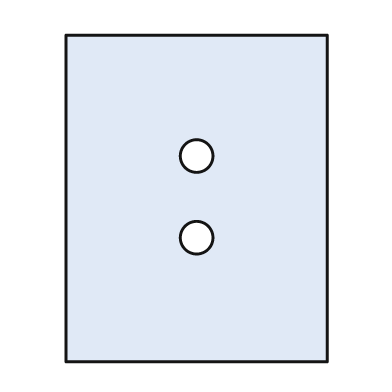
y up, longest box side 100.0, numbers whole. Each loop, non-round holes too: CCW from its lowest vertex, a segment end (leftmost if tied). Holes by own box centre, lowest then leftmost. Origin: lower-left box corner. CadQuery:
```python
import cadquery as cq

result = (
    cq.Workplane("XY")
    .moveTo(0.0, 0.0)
    .lineTo(80.0, 0.0)
    .lineTo(80.0, 100.0)
    .lineTo(0.0, 100.0)
    .close()
    .moveTo(40.0, 38.0)
    .circle(5.0)
    .moveTo(40.0, 63.0)
    .circle(5.0)
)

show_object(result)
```